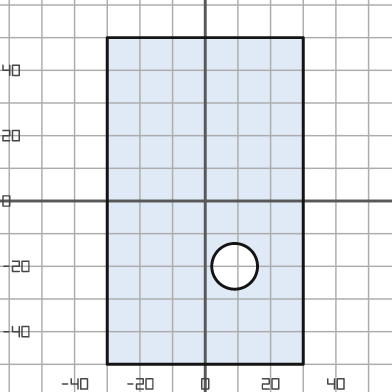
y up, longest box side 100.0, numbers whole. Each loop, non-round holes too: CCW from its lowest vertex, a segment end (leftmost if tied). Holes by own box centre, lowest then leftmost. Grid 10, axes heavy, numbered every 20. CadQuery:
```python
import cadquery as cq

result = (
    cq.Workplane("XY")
    .moveTo(-30.0, -50.0)
    .lineTo(30.0, -50.0)
    .lineTo(30.0, 50.0)
    .lineTo(-30.0, 50.0)
    .close()
    .moveTo(9.0, -20.0)
    .circle(7.0)
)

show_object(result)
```